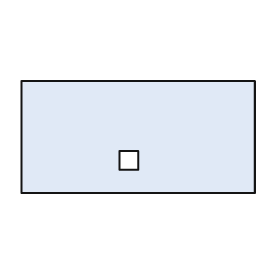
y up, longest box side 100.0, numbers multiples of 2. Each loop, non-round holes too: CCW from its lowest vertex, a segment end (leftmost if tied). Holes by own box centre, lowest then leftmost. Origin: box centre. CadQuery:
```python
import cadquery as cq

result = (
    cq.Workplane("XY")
    .moveTo(-50.0, -24.0)
    .lineTo(50.0, -24.0)
    .lineTo(50.0, 24.0)
    .lineTo(-50.0, 24.0)
    .close()
    .moveTo(-8.0, -14.0)
    .lineTo(0.0, -14.0)
    .lineTo(0.0, -6.0)
    .lineTo(-8.0, -6.0)
    .close()
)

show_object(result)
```